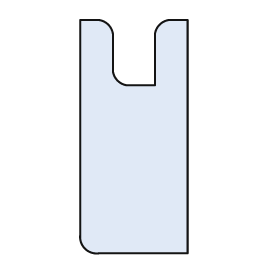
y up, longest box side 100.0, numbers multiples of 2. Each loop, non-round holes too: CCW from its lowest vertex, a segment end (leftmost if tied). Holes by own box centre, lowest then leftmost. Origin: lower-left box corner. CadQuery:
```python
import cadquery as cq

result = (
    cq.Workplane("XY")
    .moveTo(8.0, 0.0)
    .lineTo(46.0, 0.0)
    .lineTo(46.0, 100.0)
    .lineTo(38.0, 100.0)
    .threePointArc((34.0, 98.0), (32.0, 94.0))
    .lineTo(32.0, 72.0)
    .lineTo(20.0, 72.0)
    .threePointArc((16.0, 74.0), (14.0, 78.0))
    .lineTo(14.0, 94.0)
    .threePointArc((12.0, 98.0), (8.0, 100.0))
    .lineTo(0.0, 100.0)
    .lineTo(0.0, 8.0)
    .threePointArc((2.0, 2.0), (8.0, 0.0))
    .close()
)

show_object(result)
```